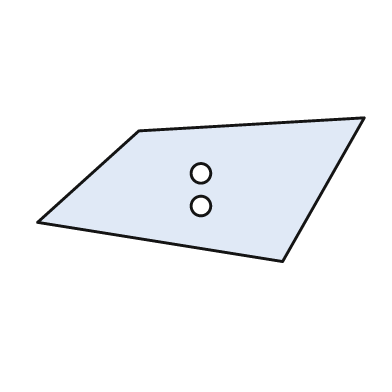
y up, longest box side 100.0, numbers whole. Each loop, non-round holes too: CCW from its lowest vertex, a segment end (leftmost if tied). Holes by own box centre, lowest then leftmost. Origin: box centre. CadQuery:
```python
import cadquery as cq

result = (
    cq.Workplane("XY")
    .moveTo(25.0, -22.0)
    .lineTo(50.0, 22.0)
    .lineTo(-19.0, 18.0)
    .lineTo(-50.0, -10.0)
    .close()
    .moveTo(0.0, -5.0)
    .circle(3.0)
    .moveTo(0.0, 5.0)
    .circle(3.0)
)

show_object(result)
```